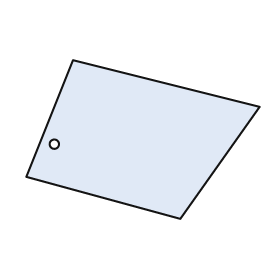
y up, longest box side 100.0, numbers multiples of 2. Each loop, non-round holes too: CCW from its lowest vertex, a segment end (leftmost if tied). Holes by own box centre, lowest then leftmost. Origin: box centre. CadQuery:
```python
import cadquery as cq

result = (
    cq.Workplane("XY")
    .moveTo(16.0, -34.0)
    .lineTo(50.0, 14.0)
    .lineTo(-30.0, 34.0)
    .lineTo(-50.0, -16.0)
    .close()
    .moveTo(-38.0, -2.0)
    .circle(2.0)
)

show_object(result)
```